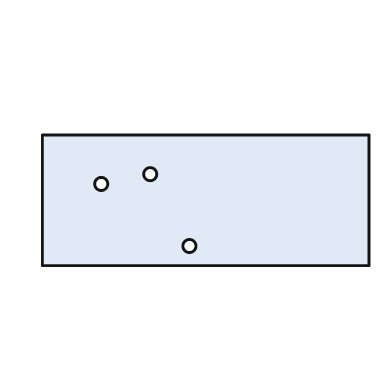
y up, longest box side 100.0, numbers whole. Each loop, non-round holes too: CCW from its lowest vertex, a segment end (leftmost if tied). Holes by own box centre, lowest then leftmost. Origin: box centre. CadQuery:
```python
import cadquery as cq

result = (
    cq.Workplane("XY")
    .moveTo(-50.0, -20.0)
    .lineTo(50.0, -20.0)
    .lineTo(50.0, 20.0)
    .lineTo(-50.0, 20.0)
    .close()
    .moveTo(-5.0, -14.0)
    .circle(2.0)
    .moveTo(-32.0, 5.0)
    .circle(2.0)
    .moveTo(-17.0, 8.0)
    .circle(2.0)
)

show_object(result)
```